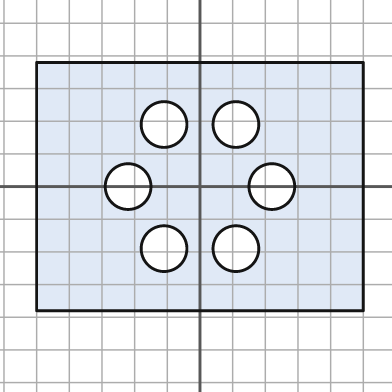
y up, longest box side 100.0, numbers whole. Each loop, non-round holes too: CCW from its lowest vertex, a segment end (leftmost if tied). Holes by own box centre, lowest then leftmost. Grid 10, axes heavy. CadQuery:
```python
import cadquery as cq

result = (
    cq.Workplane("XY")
    .moveTo(-50.0, -38.0)
    .lineTo(50.0, -38.0)
    .lineTo(50.0, 38.0)
    .lineTo(-50.0, 38.0)
    .close()
    .moveTo(-11.0, -19.0)
    .circle(7.0)
    .moveTo(11.0, -19.0)
    .circle(7.0)
    .moveTo(-22.0, 0.0)
    .circle(7.0)
    .moveTo(22.0, 0.0)
    .circle(7.0)
    .moveTo(-11.0, 19.0)
    .circle(7.0)
    .moveTo(11.0, 19.0)
    .circle(7.0)
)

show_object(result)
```